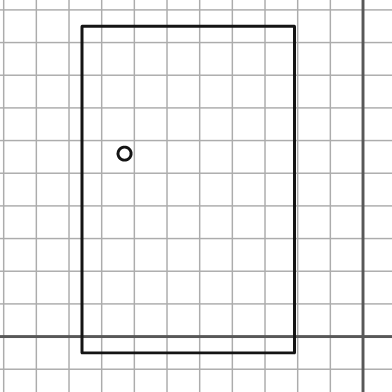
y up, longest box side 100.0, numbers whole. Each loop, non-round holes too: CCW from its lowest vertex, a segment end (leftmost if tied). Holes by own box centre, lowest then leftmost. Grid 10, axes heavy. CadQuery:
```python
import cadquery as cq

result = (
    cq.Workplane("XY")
    .moveTo(-86.0, -5.0)
    .lineTo(-21.0, -5.0)
    .lineTo(-21.0, 95.0)
    .lineTo(-86.0, 95.0)
    .close()
    .moveTo(-73.0, 56.0)
    .circle(2.0)
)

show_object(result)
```